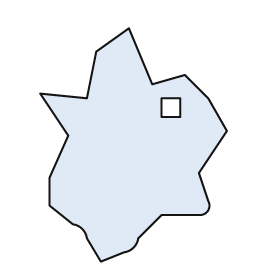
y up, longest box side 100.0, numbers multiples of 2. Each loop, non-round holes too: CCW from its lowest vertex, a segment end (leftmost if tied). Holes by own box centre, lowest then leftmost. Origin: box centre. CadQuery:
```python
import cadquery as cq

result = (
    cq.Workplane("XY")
    .moveTo(-14.0, -50.0)
    .lineTo(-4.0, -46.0)
    .threePointArc((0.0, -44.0), (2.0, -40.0))
    .lineTo(12.0, -30.0)
    .lineTo(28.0, -30.0)
    .threePointArc((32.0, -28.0), (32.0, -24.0))
    .lineTo(28.0, -12.0)
    .lineTo(40.0, 6.0)
    .lineTo(32.0, 20.0)
    .lineTo(22.0, 30.0)
    .lineTo(8.0, 26.0)
    .lineTo(-2.0, 50.0)
    .lineTo(-16.0, 40.0)
    .lineTo(-20.0, 20.0)
    .lineTo(-40.0, 22.0)
    .lineTo(-28.0, 4.0)
    .lineTo(-36.0, -14.0)
    .lineTo(-36.0, -26.0)
    .lineTo(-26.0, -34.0)
    .threePointArc((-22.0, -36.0), (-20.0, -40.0))
    .close()
    .moveTo(12.0, 12.0)
    .lineTo(20.0, 12.0)
    .lineTo(20.0, 20.0)
    .lineTo(12.0, 20.0)
    .close()
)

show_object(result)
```